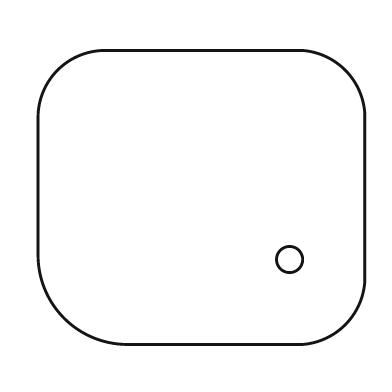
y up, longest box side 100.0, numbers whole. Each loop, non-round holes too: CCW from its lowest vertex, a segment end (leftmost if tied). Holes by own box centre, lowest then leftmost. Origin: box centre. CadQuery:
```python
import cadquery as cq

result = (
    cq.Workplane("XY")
    .moveTo(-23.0, -45.0)
    .lineTo(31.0, -45.0)
    .threePointArc((44.0, -39.0), (50.0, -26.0))
    .lineTo(50.0, 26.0)
    .threePointArc((44.0, 39.0), (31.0, 45.0))
    .lineTo(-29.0, 45.0)
    .threePointArc((-44.0, 39.0), (-50.0, 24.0))
    .lineTo(-50.0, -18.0)
    .threePointArc((-42.0, -37.0), (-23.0, -45.0))
    .close()
    .moveTo(27.0, -19.0)
    .circle(4.0)
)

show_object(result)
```